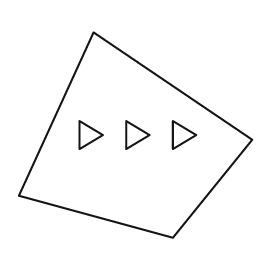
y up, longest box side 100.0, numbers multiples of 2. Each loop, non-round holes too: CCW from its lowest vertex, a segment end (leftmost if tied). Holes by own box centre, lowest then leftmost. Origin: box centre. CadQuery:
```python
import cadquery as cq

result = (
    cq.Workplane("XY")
    .moveTo(16.0, -44.0)
    .lineTo(50.0, -2.0)
    .lineTo(-18.0, 44.0)
    .lineTo(-50.0, -26.0)
    .close()
    .moveTo(-24.0, -6.0)
    .lineTo(-14.0, 0.0)
    .lineTo(-24.0, 6.0)
    .close()
    .moveTo(-4.0, -6.0)
    .lineTo(6.0, 0.0)
    .lineTo(-4.0, 6.0)
    .close()
    .moveTo(16.0, -6.0)
    .lineTo(26.0, 0.0)
    .lineTo(16.0, 6.0)
    .close()
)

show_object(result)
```